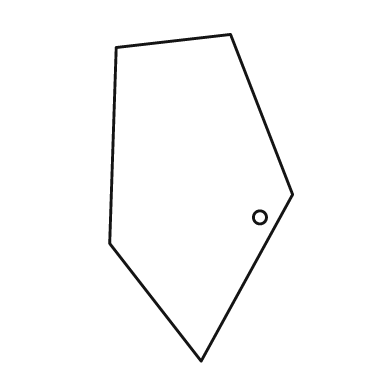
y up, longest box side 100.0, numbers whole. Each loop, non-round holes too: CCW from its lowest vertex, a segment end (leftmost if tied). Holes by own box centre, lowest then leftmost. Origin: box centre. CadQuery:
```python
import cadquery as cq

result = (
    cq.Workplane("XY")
    .moveTo(0.0, -50.0)
    .lineTo(28.0, 1.0)
    .lineTo(9.0, 50.0)
    .lineTo(-26.0, 46.0)
    .lineTo(-28.0, -14.0)
    .close()
    .moveTo(18.0, -6.0)
    .circle(2.0)
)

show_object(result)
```